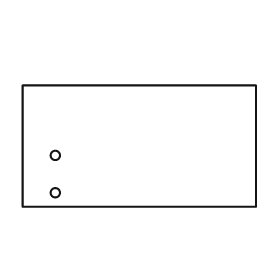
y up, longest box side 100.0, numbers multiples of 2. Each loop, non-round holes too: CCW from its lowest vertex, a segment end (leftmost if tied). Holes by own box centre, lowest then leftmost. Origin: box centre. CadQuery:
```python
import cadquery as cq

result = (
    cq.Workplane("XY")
    .moveTo(-50.0, -26.0)
    .lineTo(50.0, -26.0)
    .lineTo(50.0, 26.0)
    .lineTo(-50.0, 26.0)
    .close()
    .moveTo(-36.0, -20.0)
    .circle(2.0)
    .moveTo(-36.0, -4.0)
    .circle(2.0)
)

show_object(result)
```